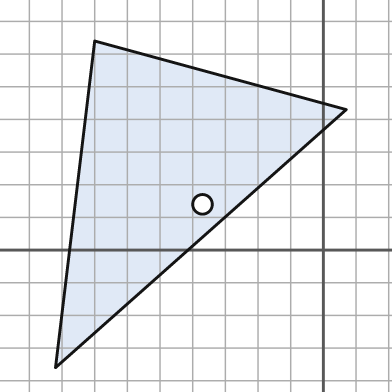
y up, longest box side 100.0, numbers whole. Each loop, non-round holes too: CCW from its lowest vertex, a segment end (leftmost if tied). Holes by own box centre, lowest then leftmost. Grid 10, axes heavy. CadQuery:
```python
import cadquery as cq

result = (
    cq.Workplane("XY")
    .moveTo(-82.0, -36.0)
    .lineTo(7.0, 43.0)
    .lineTo(-70.0, 64.0)
    .close()
    .moveTo(-37.0, 14.0)
    .circle(3.0)
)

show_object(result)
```